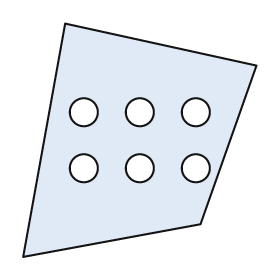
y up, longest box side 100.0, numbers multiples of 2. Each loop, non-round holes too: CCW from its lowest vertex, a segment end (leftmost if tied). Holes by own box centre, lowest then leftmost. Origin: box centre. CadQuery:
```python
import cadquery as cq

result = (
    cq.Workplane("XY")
    .moveTo(-50.0, -50.0)
    .lineTo(26.0, -36.0)
    .lineTo(50.0, 32.0)
    .lineTo(-32.0, 50.0)
    .close()
    .moveTo(-24.0, -12.0)
    .circle(6.0)
    .moveTo(0.0, -12.0)
    .circle(6.0)
    .moveTo(24.0, -12.0)
    .circle(6.0)
    .moveTo(-24.0, 12.0)
    .circle(6.0)
    .moveTo(0.0, 12.0)
    .circle(6.0)
    .moveTo(24.0, 12.0)
    .circle(6.0)
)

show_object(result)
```